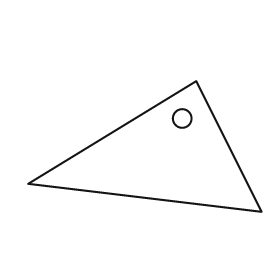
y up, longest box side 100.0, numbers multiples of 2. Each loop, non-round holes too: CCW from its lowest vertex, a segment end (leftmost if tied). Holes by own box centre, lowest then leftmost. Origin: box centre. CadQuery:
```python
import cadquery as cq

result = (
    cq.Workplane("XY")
    .moveTo(50.0, -28.0)
    .lineTo(22.0, 28.0)
    .lineTo(-50.0, -16.0)
    .close()
    .moveTo(16.0, 12.0)
    .circle(4.0)
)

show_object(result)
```